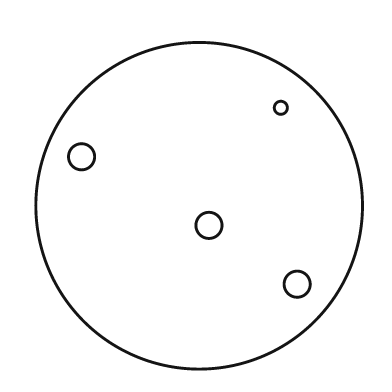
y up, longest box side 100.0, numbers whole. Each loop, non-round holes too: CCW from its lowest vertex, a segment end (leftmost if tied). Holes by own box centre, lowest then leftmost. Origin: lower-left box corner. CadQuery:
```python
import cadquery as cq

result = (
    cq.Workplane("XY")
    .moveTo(50.0, 50.0)
    .circle(50.0)
    .moveTo(80.0, 26.0)
    .circle(4.0)
    .moveTo(53.0, 44.0)
    .circle(4.0)
    .moveTo(14.0, 65.0)
    .circle(4.0)
    .moveTo(75.0, 80.0)
    .circle(2.0)
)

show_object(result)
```